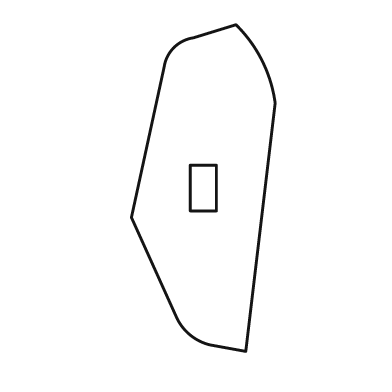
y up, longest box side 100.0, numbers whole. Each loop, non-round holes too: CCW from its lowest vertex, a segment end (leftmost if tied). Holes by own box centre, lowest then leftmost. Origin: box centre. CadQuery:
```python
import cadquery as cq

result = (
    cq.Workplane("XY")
    .moveTo(13.0, -50.0)
    .lineTo(22.0, 26.0)
    .threePointArc((18.0, 39.0), (10.0, 50.0))
    .lineTo(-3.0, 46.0)
    .threePointArc((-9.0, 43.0), (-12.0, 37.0))
    .lineTo(-22.0, -9.0)
    .lineTo(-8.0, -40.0)
    .threePointArc((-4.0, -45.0), (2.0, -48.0))
    .close()
    .moveTo(-4.0, -7.0)
    .lineTo(4.0, -7.0)
    .lineTo(4.0, 7.0)
    .lineTo(-4.0, 7.0)
    .close()
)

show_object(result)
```